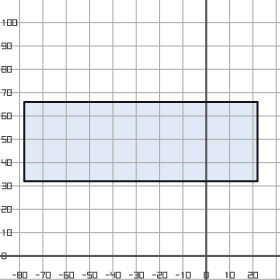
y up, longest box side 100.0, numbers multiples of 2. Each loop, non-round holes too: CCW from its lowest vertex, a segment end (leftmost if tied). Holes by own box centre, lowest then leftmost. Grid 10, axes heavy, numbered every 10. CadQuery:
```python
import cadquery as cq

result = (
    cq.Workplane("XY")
    .moveTo(-78.0, 32.0)
    .lineTo(22.0, 32.0)
    .lineTo(22.0, 66.0)
    .lineTo(-78.0, 66.0)
    .close()
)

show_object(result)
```